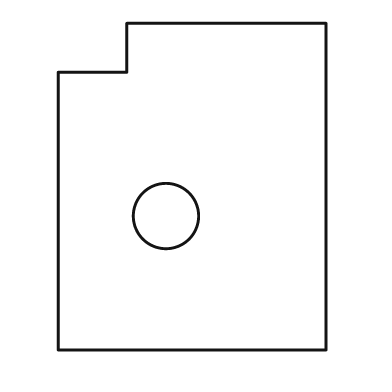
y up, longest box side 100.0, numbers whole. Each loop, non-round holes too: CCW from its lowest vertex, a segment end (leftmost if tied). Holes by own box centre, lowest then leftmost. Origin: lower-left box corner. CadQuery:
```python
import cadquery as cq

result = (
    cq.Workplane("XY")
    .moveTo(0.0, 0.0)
    .lineTo(82.0, 0.0)
    .lineTo(82.0, 100.0)
    .lineTo(21.0, 100.0)
    .lineTo(21.0, 85.0)
    .lineTo(0.0, 85.0)
    .close()
    .moveTo(33.0, 41.0)
    .circle(10.0)
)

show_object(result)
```